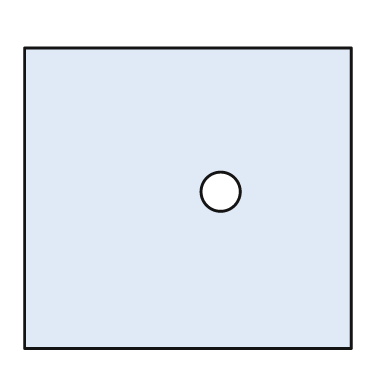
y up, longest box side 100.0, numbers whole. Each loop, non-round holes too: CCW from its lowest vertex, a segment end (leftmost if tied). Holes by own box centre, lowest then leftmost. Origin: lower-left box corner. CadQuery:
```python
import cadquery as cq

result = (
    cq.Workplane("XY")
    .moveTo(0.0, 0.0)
    .lineTo(100.0, 0.0)
    .lineTo(100.0, 92.0)
    .lineTo(0.0, 92.0)
    .close()
    .moveTo(60.0, 48.0)
    .circle(6.0)
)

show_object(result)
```